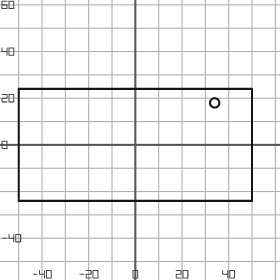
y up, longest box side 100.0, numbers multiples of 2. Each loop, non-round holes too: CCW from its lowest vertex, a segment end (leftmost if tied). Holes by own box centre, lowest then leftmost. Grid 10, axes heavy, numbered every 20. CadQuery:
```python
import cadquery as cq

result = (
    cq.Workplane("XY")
    .moveTo(-50.0, -24.0)
    .lineTo(50.0, -24.0)
    .lineTo(50.0, 24.0)
    .lineTo(-50.0, 24.0)
    .close()
    .moveTo(34.0, 18.0)
    .circle(2.0)
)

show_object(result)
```